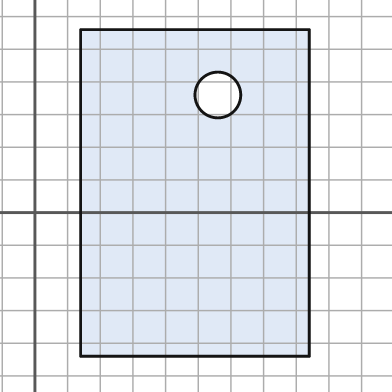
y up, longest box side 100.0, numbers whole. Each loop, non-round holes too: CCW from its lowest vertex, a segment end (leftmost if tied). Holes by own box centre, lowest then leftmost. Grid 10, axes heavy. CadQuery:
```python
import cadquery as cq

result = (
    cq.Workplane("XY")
    .moveTo(14.0, -44.0)
    .lineTo(84.0, -44.0)
    .lineTo(84.0, 56.0)
    .lineTo(14.0, 56.0)
    .close()
    .moveTo(56.0, 36.0)
    .circle(7.0)
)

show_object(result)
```